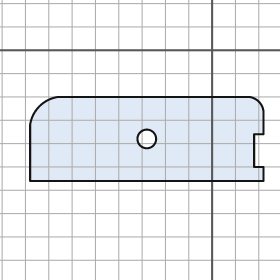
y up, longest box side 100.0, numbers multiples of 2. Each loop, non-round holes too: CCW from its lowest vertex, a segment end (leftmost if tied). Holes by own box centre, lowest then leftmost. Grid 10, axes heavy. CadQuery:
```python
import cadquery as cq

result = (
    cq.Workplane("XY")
    .moveTo(-78.0, -56.0)
    .lineTo(22.0, -56.0)
    .lineTo(22.0, -50.0)
    .lineTo(18.0, -50.0)
    .lineTo(18.0, -36.0)
    .lineTo(22.0, -36.0)
    .lineTo(22.0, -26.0)
    .threePointArc((20.0, -22.0), (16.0, -20.0))
    .lineTo(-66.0, -20.0)
    .threePointArc((-74.0, -24.0), (-78.0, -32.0))
    .close()
    .moveTo(-28.0, -38.0)
    .circle(4.0)
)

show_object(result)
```